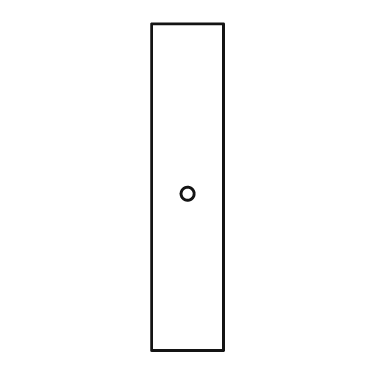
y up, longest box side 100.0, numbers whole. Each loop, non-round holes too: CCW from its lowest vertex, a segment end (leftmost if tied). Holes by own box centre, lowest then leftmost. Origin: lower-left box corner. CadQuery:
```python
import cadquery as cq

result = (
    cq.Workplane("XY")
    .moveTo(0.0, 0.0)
    .lineTo(22.0, 0.0)
    .lineTo(22.0, 100.0)
    .lineTo(0.0, 100.0)
    .close()
    .moveTo(11.0, 48.0)
    .circle(2.0)
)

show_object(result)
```